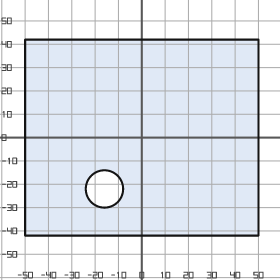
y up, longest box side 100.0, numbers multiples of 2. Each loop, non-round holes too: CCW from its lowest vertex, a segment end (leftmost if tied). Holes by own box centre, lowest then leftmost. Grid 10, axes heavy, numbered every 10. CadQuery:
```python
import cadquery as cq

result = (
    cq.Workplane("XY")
    .moveTo(-50.0, -42.0)
    .lineTo(50.0, -42.0)
    .lineTo(50.0, 42.0)
    .lineTo(-50.0, 42.0)
    .close()
    .moveTo(-16.0, -22.0)
    .circle(8.0)
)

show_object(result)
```